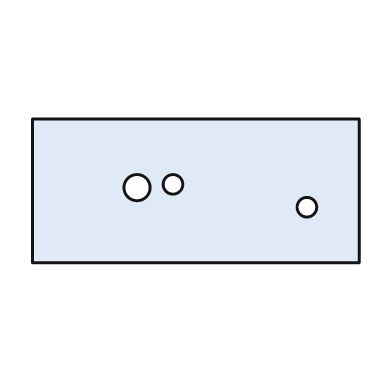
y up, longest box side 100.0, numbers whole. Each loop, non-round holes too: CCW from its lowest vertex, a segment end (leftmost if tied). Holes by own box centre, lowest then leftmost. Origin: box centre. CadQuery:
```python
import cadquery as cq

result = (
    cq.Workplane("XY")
    .moveTo(-50.0, -22.0)
    .lineTo(50.0, -22.0)
    .lineTo(50.0, 22.0)
    .lineTo(-50.0, 22.0)
    .close()
    .moveTo(34.0, -5.0)
    .circle(3.0)
    .moveTo(-18.0, 1.0)
    .circle(4.0)
    .moveTo(-7.0, 2.0)
    .circle(3.0)
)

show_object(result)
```